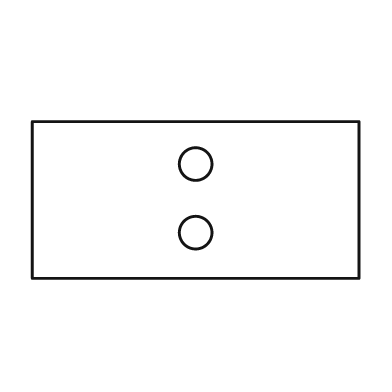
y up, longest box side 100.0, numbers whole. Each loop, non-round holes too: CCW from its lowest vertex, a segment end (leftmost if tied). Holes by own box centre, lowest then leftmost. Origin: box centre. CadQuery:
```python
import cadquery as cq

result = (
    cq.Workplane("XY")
    .moveTo(-50.0, -24.0)
    .lineTo(50.0, -24.0)
    .lineTo(50.0, 24.0)
    .lineTo(-50.0, 24.0)
    .close()
    .moveTo(0.0, -10.0)
    .circle(5.0)
    .moveTo(0.0, 11.0)
    .circle(5.0)
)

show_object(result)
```